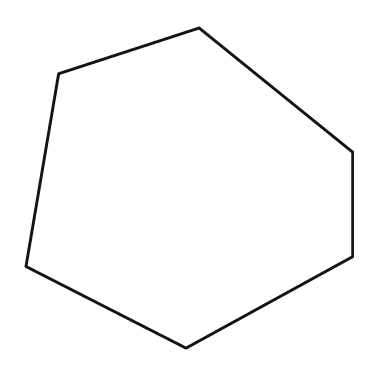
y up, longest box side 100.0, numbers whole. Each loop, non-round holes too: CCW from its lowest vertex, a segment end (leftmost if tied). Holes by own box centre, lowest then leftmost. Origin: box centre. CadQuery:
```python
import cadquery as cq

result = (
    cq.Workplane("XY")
    .moveTo(-1.0, -49.0)
    .lineTo(50.0, -21.0)
    .lineTo(50.0, 11.0)
    .lineTo(3.0, 49.0)
    .lineTo(-40.0, 35.0)
    .lineTo(-50.0, -24.0)
    .close()
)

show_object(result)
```